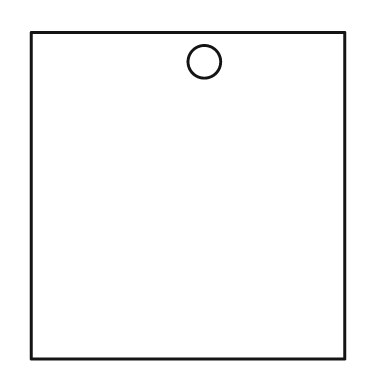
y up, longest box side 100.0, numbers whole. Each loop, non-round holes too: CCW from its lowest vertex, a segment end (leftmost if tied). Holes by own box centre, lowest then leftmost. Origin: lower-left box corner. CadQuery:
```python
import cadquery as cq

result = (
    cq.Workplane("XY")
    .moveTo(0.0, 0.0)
    .lineTo(96.0, 0.0)
    .lineTo(96.0, 100.0)
    .lineTo(0.0, 100.0)
    .close()
    .moveTo(53.0, 91.0)
    .circle(5.0)
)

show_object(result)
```